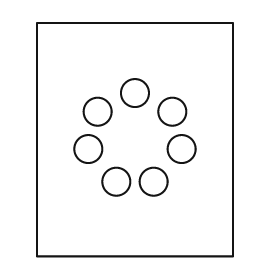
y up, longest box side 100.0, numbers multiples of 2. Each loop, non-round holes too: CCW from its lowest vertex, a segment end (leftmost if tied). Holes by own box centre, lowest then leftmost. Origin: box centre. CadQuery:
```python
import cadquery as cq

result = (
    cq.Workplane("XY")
    .moveTo(-42.0, -50.0)
    .lineTo(42.0, -50.0)
    .lineTo(42.0, 50.0)
    .lineTo(-42.0, 50.0)
    .close()
    .moveTo(-8.0, -18.0)
    .circle(6.0)
    .moveTo(8.0, -18.0)
    .circle(6.0)
    .moveTo(-20.0, -4.0)
    .circle(6.0)
    .moveTo(20.0, -4.0)
    .circle(6.0)
    .moveTo(-16.0, 12.0)
    .circle(6.0)
    .moveTo(16.0, 12.0)
    .circle(6.0)
    .moveTo(0.0, 20.0)
    .circle(6.0)
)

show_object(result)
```